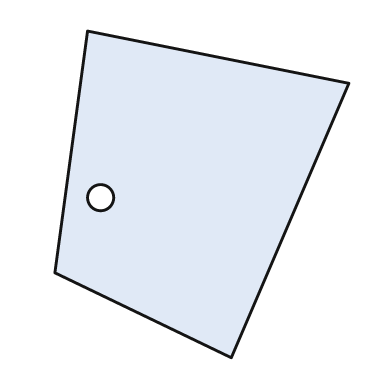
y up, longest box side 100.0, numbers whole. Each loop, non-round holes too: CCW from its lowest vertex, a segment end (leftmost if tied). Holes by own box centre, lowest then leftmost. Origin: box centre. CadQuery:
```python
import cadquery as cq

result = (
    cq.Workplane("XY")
    .moveTo(9.0, -50.0)
    .lineTo(45.0, 34.0)
    .lineTo(-35.0, 50.0)
    .lineTo(-45.0, -24.0)
    .close()
    .moveTo(-31.0, -1.0)
    .circle(4.0)
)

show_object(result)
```